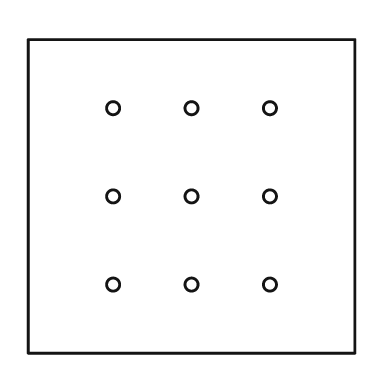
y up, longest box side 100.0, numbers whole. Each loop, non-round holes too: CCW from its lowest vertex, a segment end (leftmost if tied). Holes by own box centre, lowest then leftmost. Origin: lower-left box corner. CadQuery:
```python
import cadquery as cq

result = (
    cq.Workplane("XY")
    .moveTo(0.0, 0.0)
    .lineTo(100.0, 0.0)
    .lineTo(100.0, 96.0)
    .lineTo(0.0, 96.0)
    .close()
    .moveTo(26.0, 21.0)
    .circle(2.0)
    .moveTo(50.0, 21.0)
    .circle(2.0)
    .moveTo(74.0, 21.0)
    .circle(2.0)
    .moveTo(26.0, 48.0)
    .circle(2.0)
    .moveTo(50.0, 48.0)
    .circle(2.0)
    .moveTo(74.0, 48.0)
    .circle(2.0)
    .moveTo(26.0, 75.0)
    .circle(2.0)
    .moveTo(50.0, 75.0)
    .circle(2.0)
    .moveTo(74.0, 75.0)
    .circle(2.0)
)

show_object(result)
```